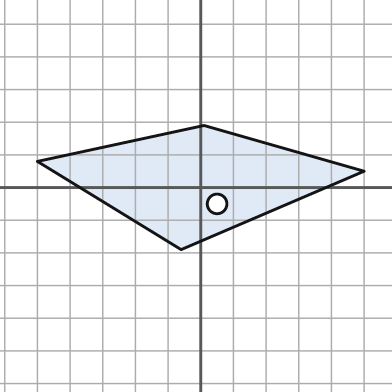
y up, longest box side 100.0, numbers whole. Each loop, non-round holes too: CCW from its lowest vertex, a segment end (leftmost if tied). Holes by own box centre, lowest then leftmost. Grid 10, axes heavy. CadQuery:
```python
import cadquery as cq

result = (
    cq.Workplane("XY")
    .moveTo(-6.0, -19.0)
    .lineTo(50.0, 5.0)
    .lineTo(1.0, 19.0)
    .lineTo(-50.0, 8.0)
    .close()
    .moveTo(5.0, -5.0)
    .circle(3.0)
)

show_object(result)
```